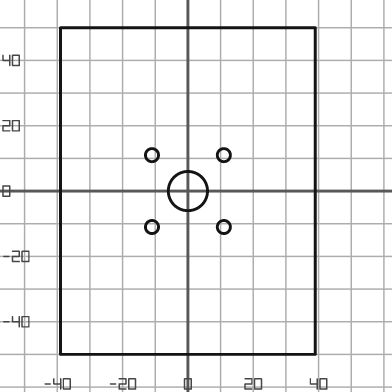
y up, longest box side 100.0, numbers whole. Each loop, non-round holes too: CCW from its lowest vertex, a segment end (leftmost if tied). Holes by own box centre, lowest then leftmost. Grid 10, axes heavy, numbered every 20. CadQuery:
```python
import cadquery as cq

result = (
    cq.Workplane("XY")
    .moveTo(-39.0, -50.0)
    .lineTo(39.0, -50.0)
    .lineTo(39.0, 50.0)
    .lineTo(-39.0, 50.0)
    .close()
    .moveTo(-11.0, -11.0)
    .circle(2.0)
    .moveTo(11.0, -11.0)
    .circle(2.0)
    .moveTo(0.0, 0.0)
    .circle(6.0)
    .moveTo(-11.0, 11.0)
    .circle(2.0)
    .moveTo(11.0, 11.0)
    .circle(2.0)
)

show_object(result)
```